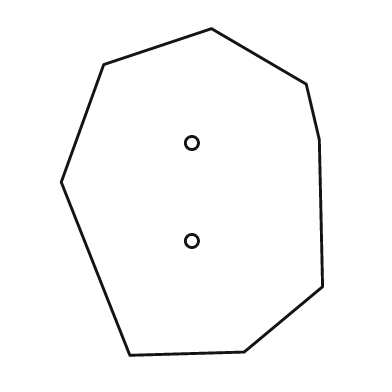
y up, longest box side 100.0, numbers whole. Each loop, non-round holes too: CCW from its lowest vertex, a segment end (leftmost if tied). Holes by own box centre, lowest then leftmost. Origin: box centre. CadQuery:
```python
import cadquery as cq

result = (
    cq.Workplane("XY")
    .moveTo(-19.0, -50.0)
    .lineTo(16.0, -49.0)
    .lineTo(40.0, -29.0)
    .lineTo(39.0, 16.0)
    .lineTo(35.0, 33.0)
    .lineTo(6.0, 50.0)
    .lineTo(-27.0, 39.0)
    .lineTo(-40.0, 3.0)
    .close()
    .moveTo(0.0, -15.0)
    .circle(2.0)
    .moveTo(0.0, 15.0)
    .circle(2.0)
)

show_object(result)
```